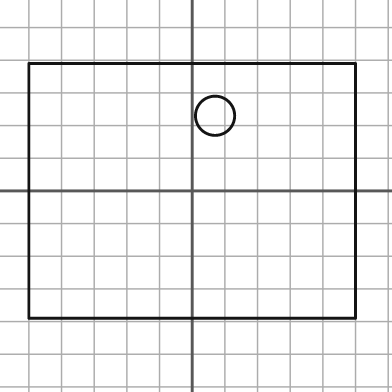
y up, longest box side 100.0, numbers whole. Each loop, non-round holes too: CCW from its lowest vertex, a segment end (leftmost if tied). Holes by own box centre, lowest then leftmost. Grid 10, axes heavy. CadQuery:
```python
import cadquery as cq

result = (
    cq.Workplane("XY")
    .moveTo(-50.0, -39.0)
    .lineTo(50.0, -39.0)
    .lineTo(50.0, 39.0)
    .lineTo(-50.0, 39.0)
    .close()
    .moveTo(7.0, 23.0)
    .circle(6.0)
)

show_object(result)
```